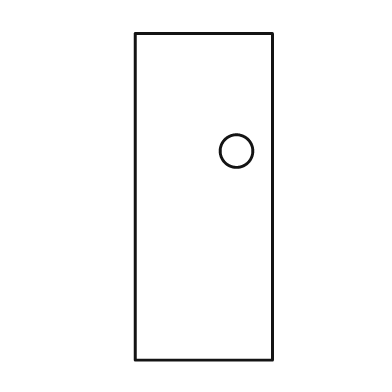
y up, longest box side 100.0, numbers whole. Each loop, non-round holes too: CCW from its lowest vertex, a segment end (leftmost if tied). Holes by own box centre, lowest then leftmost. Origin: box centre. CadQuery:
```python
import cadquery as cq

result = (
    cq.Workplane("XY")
    .moveTo(-21.0, -50.0)
    .lineTo(21.0, -50.0)
    .lineTo(21.0, 50.0)
    .lineTo(-21.0, 50.0)
    .close()
    .moveTo(10.0, 14.0)
    .circle(5.0)
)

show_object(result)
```